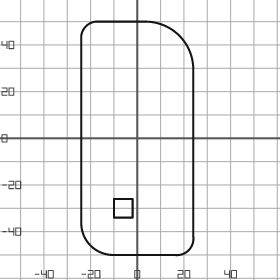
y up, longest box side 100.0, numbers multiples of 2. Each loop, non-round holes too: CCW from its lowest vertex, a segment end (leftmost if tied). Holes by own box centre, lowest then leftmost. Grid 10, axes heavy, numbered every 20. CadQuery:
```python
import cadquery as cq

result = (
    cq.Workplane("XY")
    .moveTo(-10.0, -50.0)
    .lineTo(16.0, -50.0)
    .threePointArc((22.0, -48.0), (24.0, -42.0))
    .lineTo(24.0, 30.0)
    .threePointArc((18.0, 44.0), (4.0, 50.0))
    .lineTo(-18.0, 50.0)
    .threePointArc((-22.0, 48.0), (-24.0, 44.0))
    .lineTo(-24.0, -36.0)
    .threePointArc((-20.0, -46.0), (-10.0, -50.0))
    .close()
    .moveTo(-10.0, -34.0)
    .lineTo(-2.0, -34.0)
    .lineTo(-2.0, -26.0)
    .lineTo(-10.0, -26.0)
    .close()
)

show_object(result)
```